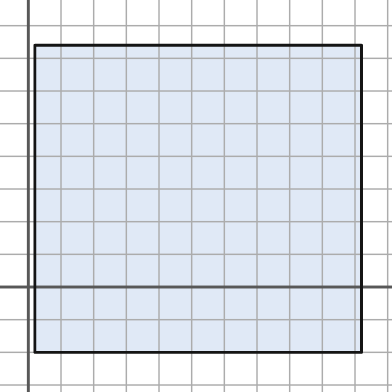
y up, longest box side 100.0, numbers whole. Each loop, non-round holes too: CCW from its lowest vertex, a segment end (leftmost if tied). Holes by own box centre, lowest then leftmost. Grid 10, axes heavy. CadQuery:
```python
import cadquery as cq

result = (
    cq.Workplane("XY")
    .moveTo(2.0, -20.0)
    .lineTo(102.0, -20.0)
    .lineTo(102.0, 74.0)
    .lineTo(2.0, 74.0)
    .close()
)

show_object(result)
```